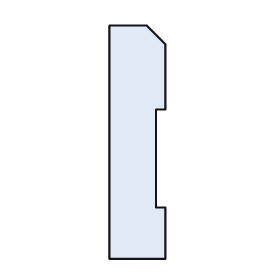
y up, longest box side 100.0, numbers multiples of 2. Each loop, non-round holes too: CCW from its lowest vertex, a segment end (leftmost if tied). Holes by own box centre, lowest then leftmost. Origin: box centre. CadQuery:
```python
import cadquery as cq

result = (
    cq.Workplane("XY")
    .moveTo(-12.0, -50.0)
    .lineTo(12.0, -50.0)
    .lineTo(12.0, -28.0)
    .lineTo(8.0, -28.0)
    .lineTo(8.0, 14.0)
    .lineTo(12.0, 14.0)
    .lineTo(12.0, 42.0)
    .lineTo(4.0, 50.0)
    .lineTo(-12.0, 50.0)
    .close()
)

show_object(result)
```